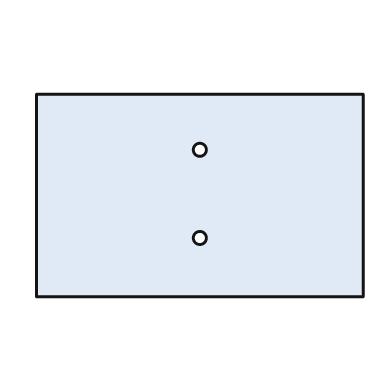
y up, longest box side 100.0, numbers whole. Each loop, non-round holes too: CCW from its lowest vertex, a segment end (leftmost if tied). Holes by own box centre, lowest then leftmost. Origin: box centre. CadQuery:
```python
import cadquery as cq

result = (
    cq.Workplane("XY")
    .moveTo(-50.0, -31.0)
    .lineTo(50.0, -31.0)
    .lineTo(50.0, 31.0)
    .lineTo(-50.0, 31.0)
    .close()
    .moveTo(0.0, -13.0)
    .circle(2.0)
    .moveTo(0.0, 14.0)
    .circle(2.0)
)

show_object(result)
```